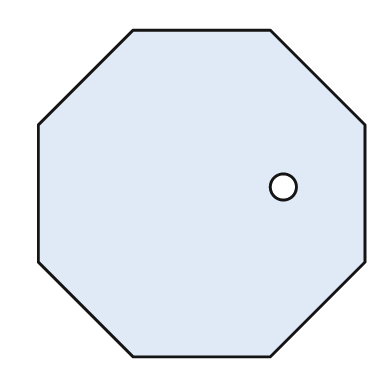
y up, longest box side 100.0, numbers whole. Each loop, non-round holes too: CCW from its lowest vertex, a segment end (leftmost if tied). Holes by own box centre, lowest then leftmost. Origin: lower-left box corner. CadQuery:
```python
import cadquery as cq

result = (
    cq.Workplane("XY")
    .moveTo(29.0, 0.0)
    .lineTo(71.0, 0.0)
    .lineTo(100.0, 29.0)
    .lineTo(100.0, 71.0)
    .lineTo(71.0, 100.0)
    .lineTo(29.0, 100.0)
    .lineTo(0.0, 71.0)
    .lineTo(0.0, 29.0)
    .close()
    .moveTo(75.0, 52.0)
    .circle(4.0)
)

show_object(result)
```